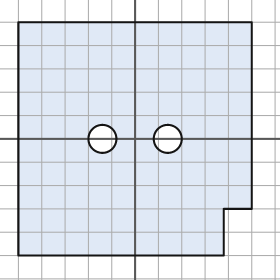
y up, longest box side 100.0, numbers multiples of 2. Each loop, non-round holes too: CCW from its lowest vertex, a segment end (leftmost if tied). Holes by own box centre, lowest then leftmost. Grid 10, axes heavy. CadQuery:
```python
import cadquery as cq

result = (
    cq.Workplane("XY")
    .moveTo(-50.0, -50.0)
    .lineTo(38.0, -50.0)
    .lineTo(38.0, -30.0)
    .lineTo(50.0, -30.0)
    .lineTo(50.0, 50.0)
    .lineTo(-50.0, 50.0)
    .close()
    .moveTo(-14.0, 0.0)
    .circle(6.0)
    .moveTo(14.0, 0.0)
    .circle(6.0)
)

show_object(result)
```